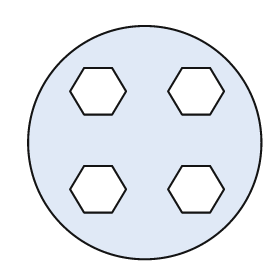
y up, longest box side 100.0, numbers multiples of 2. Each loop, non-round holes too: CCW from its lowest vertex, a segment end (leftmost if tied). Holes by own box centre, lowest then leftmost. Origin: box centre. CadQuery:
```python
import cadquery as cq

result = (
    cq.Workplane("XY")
    .moveTo(0.0, 0.0)
    .circle(50.0)
    .moveTo(-26.0, -30.0)
    .lineTo(-14.0, -30.0)
    .lineTo(-8.0, -20.0)
    .lineTo(-14.0, -10.0)
    .lineTo(-26.0, -10.0)
    .lineTo(-32.0, -20.0)
    .close()
    .moveTo(16.0, -30.0)
    .lineTo(28.0, -30.0)
    .lineTo(34.0, -20.0)
    .lineTo(28.0, -10.0)
    .lineTo(16.0, -10.0)
    .lineTo(10.0, -20.0)
    .close()
    .moveTo(-26.0, 12.0)
    .lineTo(-14.0, 12.0)
    .lineTo(-8.0, 22.0)
    .lineTo(-14.0, 32.0)
    .lineTo(-26.0, 32.0)
    .lineTo(-32.0, 22.0)
    .close()
    .moveTo(16.0, 12.0)
    .lineTo(28.0, 12.0)
    .lineTo(34.0, 22.0)
    .lineTo(28.0, 32.0)
    .lineTo(16.0, 32.0)
    .lineTo(10.0, 22.0)
    .close()
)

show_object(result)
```